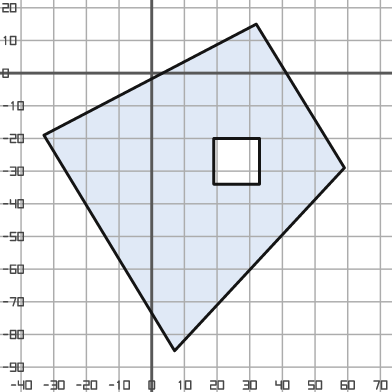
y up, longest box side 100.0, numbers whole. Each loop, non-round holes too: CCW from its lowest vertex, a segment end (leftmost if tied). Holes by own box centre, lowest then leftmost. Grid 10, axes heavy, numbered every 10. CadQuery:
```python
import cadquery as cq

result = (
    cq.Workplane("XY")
    .moveTo(7.0, -85.0)
    .lineTo(59.0, -29.0)
    .lineTo(32.0, 15.0)
    .lineTo(-33.0, -19.0)
    .close()
    .moveTo(19.0, -34.0)
    .lineTo(33.0, -34.0)
    .lineTo(33.0, -20.0)
    .lineTo(19.0, -20.0)
    .close()
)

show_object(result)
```